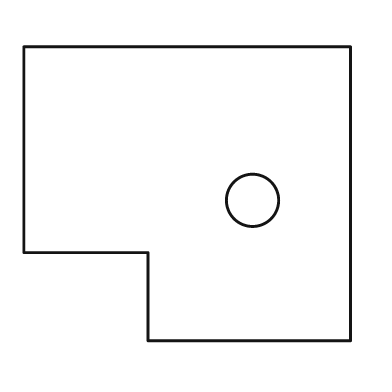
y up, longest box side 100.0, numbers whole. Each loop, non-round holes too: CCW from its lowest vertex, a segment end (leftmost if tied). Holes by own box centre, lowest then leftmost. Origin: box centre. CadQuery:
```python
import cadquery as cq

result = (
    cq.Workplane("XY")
    .moveTo(-12.0, -45.0)
    .lineTo(50.0, -45.0)
    .lineTo(50.0, 45.0)
    .lineTo(-50.0, 45.0)
    .lineTo(-50.0, -18.0)
    .lineTo(-12.0, -18.0)
    .close()
    .moveTo(20.0, -2.0)
    .circle(8.0)
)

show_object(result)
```